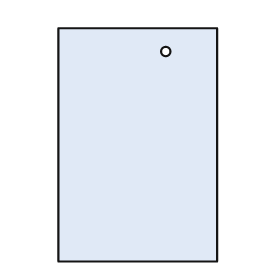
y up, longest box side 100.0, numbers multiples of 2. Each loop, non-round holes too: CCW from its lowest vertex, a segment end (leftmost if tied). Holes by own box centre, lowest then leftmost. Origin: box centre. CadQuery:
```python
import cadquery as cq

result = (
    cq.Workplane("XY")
    .moveTo(-34.0, -50.0)
    .lineTo(34.0, -50.0)
    .lineTo(34.0, 50.0)
    .lineTo(-34.0, 50.0)
    .close()
    .moveTo(12.0, 40.0)
    .circle(2.0)
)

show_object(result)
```